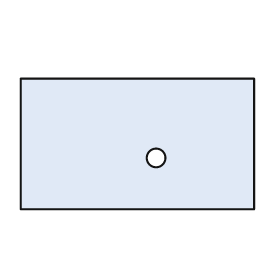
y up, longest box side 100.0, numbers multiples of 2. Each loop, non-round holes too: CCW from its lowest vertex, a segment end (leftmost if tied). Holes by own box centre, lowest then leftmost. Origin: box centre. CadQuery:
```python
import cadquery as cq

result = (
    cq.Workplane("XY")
    .moveTo(-50.0, -28.0)
    .lineTo(50.0, -28.0)
    .lineTo(50.0, 28.0)
    .lineTo(-50.0, 28.0)
    .close()
    .moveTo(8.0, -6.0)
    .circle(4.0)
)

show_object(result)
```